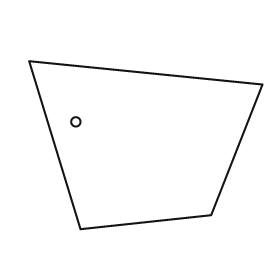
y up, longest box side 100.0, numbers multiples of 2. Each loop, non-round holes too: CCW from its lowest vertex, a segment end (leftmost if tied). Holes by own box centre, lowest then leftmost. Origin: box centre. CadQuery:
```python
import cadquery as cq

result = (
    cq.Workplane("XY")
    .moveTo(-28.0, -36.0)
    .lineTo(28.0, -30.0)
    .lineTo(50.0, 26.0)
    .lineTo(-50.0, 36.0)
    .close()
    .moveTo(-30.0, 10.0)
    .circle(2.0)
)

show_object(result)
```